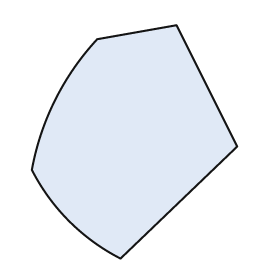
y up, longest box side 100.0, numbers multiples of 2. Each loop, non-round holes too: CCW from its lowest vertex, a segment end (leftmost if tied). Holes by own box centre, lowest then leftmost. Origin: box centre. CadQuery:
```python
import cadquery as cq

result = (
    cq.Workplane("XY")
    .moveTo(-6.0, -50.0)
    .lineTo(44.0, -2.0)
    .lineTo(18.0, 50.0)
    .lineTo(-16.0, 44.0)
    .threePointArc((-34.0, 18.0), (-44.0, -12.0))
    .threePointArc((-28.0, -34.0), (-6.0, -50.0))
    .close()
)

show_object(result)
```